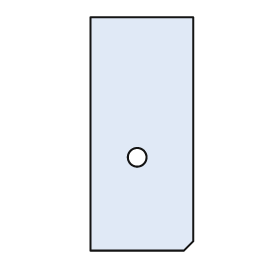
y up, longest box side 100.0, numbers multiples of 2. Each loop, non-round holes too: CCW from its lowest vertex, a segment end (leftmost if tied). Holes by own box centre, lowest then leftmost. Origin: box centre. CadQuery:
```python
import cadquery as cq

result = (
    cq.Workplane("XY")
    .moveTo(-22.0, -50.0)
    .lineTo(18.0, -50.0)
    .lineTo(22.0, -46.0)
    .lineTo(22.0, 50.0)
    .lineTo(-22.0, 50.0)
    .close()
    .moveTo(-2.0, -10.0)
    .circle(4.0)
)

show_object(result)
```